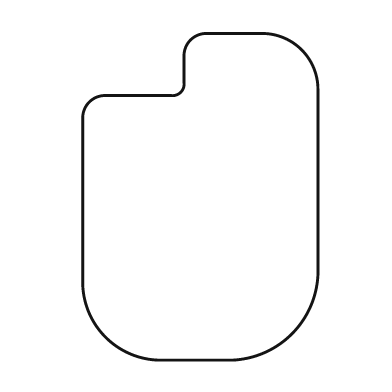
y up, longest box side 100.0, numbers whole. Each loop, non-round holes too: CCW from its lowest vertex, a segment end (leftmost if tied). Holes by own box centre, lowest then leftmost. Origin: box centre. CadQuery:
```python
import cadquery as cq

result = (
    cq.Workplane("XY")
    .moveTo(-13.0, -50.0)
    .lineTo(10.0, -50.0)
    .threePointArc((28.0, -42.0), (36.0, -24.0))
    .lineTo(36.0, 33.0)
    .threePointArc((31.0, 45.0), (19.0, 50.0))
    .lineTo(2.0, 50.0)
    .threePointArc((-3.0, 48.0), (-5.0, 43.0))
    .lineTo(-5.0, 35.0)
    .threePointArc((-6.0, 32.0), (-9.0, 31.0))
    .lineTo(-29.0, 31.0)
    .threePointArc((-34.0, 29.0), (-36.0, 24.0))
    .lineTo(-36.0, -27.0)
    .threePointArc((-29.0, -43.0), (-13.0, -50.0))
    .close()
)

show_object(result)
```